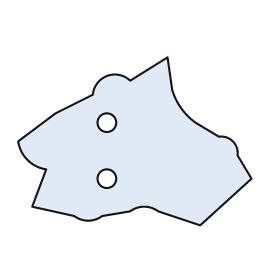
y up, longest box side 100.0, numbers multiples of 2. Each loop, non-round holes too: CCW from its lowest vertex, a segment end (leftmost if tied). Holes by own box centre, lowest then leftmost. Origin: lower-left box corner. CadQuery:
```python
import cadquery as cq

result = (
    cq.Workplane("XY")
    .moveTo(78.0, 0.0)
    .lineTo(100.0, 20.0)
    .lineTo(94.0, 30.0)
    .threePointArc((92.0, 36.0), (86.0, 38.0))
    .lineTo(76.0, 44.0)
    .threePointArc((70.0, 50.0), (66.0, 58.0))
    .lineTo(64.0, 72.0)
    .lineTo(48.0, 62.0)
    .threePointArc((38.0, 64.0), (32.0, 56.0))
    .lineTo(16.0, 48.0)
    .lineTo(0.0, 36.0)
    .threePointArc((4.0, 28.0), (12.0, 24.0))
    .lineTo(6.0, 8.0)
    .lineTo(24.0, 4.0)
    .threePointArc((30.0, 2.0), (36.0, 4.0))
    .lineTo(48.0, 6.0)
    .threePointArc((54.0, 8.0), (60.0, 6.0))
    .close()
    .moveTo(38.0, 20.0)
    .circle(4.0)
    .moveTo(38.0, 44.0)
    .circle(4.0)
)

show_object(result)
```